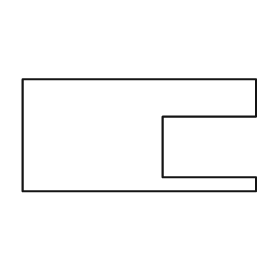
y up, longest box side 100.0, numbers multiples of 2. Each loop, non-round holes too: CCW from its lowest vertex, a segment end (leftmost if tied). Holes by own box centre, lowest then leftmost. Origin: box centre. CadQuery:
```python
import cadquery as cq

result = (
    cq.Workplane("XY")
    .moveTo(-50.0, -24.0)
    .lineTo(50.0, -24.0)
    .lineTo(50.0, -18.0)
    .lineTo(10.0, -18.0)
    .lineTo(10.0, 8.0)
    .lineTo(50.0, 8.0)
    .lineTo(50.0, 24.0)
    .lineTo(-50.0, 24.0)
    .close()
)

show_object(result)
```